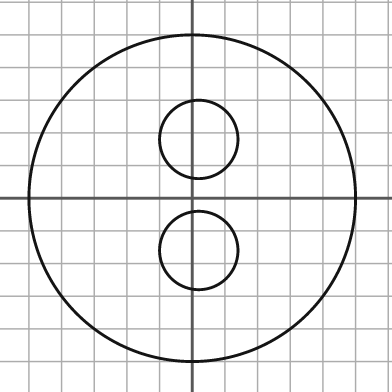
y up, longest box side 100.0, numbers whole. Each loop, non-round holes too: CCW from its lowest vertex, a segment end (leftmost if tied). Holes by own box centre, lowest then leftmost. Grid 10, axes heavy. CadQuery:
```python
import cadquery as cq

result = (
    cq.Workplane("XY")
    .moveTo(0.0, 0.0)
    .circle(50.0)
    .moveTo(2.0, -16.0)
    .circle(12.0)
    .moveTo(2.0, 18.0)
    .circle(12.0)
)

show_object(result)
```